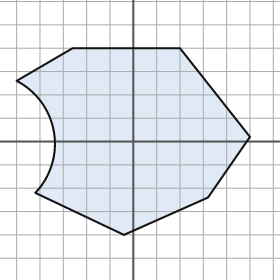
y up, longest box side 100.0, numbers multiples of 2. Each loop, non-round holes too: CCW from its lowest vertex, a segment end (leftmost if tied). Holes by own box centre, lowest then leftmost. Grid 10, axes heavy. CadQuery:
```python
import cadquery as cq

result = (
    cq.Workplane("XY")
    .moveTo(-4.0, -40.0)
    .lineTo(32.0, -24.0)
    .lineTo(50.0, 2.0)
    .lineTo(20.0, 40.0)
    .lineTo(-26.0, 40.0)
    .lineTo(-50.0, 26.0)
    .threePointArc((-34.0, 4.0), (-42.0, -22.0))
    .close()
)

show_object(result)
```